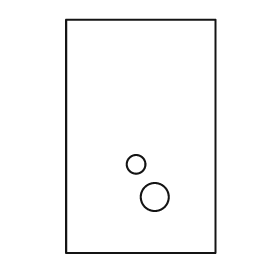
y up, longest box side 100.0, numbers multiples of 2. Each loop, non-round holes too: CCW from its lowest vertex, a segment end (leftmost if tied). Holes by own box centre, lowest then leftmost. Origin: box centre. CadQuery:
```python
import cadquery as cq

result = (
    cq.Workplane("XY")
    .moveTo(-32.0, -50.0)
    .lineTo(32.0, -50.0)
    .lineTo(32.0, 50.0)
    .lineTo(-32.0, 50.0)
    .close()
    .moveTo(6.0, -26.0)
    .circle(6.0)
    .moveTo(-2.0, -12.0)
    .circle(4.0)
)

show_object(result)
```